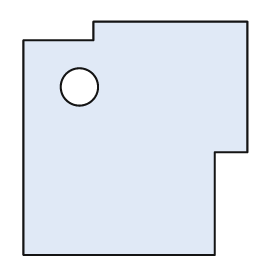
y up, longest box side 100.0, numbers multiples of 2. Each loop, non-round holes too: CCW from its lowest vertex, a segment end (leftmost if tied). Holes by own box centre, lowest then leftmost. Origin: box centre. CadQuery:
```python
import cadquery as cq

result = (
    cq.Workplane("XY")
    .moveTo(-48.0, -50.0)
    .lineTo(34.0, -50.0)
    .lineTo(34.0, -6.0)
    .lineTo(48.0, -6.0)
    .lineTo(48.0, 50.0)
    .lineTo(-18.0, 50.0)
    .lineTo(-18.0, 42.0)
    .lineTo(-48.0, 42.0)
    .close()
    .moveTo(-24.0, 22.0)
    .circle(8.0)
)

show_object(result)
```